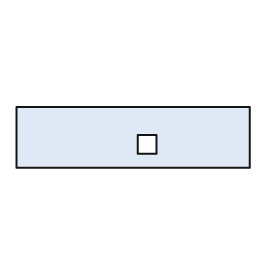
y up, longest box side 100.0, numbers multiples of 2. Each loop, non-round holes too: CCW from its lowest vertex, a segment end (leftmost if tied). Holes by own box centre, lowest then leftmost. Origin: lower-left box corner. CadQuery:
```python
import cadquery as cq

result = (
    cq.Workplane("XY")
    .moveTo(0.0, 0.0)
    .lineTo(100.0, 0.0)
    .lineTo(100.0, 26.0)
    .lineTo(0.0, 26.0)
    .close()
    .moveTo(52.0, 6.0)
    .lineTo(60.0, 6.0)
    .lineTo(60.0, 14.0)
    .lineTo(52.0, 14.0)
    .close()
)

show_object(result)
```